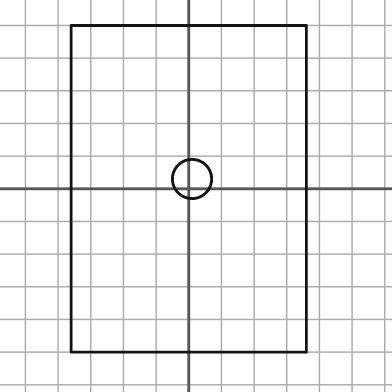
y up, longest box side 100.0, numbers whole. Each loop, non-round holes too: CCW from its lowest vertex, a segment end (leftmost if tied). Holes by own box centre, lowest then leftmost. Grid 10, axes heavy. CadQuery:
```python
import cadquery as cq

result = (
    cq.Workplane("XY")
    .moveTo(-36.0, -50.0)
    .lineTo(36.0, -50.0)
    .lineTo(36.0, 50.0)
    .lineTo(-36.0, 50.0)
    .close()
    .moveTo(1.0, 3.0)
    .circle(6.0)
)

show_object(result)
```